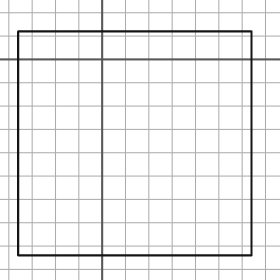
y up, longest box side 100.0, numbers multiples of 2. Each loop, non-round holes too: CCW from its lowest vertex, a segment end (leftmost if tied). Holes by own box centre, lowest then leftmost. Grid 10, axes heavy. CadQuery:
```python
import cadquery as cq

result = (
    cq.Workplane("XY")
    .moveTo(-36.0, -84.0)
    .lineTo(64.0, -84.0)
    .lineTo(64.0, 12.0)
    .lineTo(-36.0, 12.0)
    .close()
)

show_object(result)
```